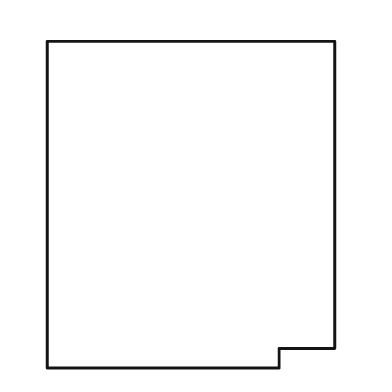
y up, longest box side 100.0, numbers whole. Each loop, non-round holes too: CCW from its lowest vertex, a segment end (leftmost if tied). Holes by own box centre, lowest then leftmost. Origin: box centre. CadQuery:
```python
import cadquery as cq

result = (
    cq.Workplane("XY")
    .moveTo(-44.0, -50.0)
    .lineTo(27.0, -50.0)
    .lineTo(27.0, -44.0)
    .lineTo(44.0, -44.0)
    .lineTo(44.0, 50.0)
    .lineTo(-44.0, 50.0)
    .close()
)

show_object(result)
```